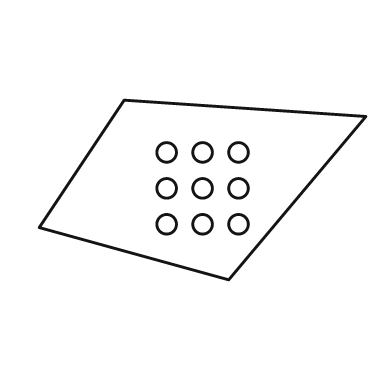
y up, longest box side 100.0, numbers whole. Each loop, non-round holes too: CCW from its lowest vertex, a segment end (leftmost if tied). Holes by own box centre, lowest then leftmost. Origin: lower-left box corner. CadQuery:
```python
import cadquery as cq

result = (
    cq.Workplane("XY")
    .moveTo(58.0, 0.0)
    .lineTo(100.0, 50.0)
    .lineTo(26.0, 55.0)
    .lineTo(0.0, 16.0)
    .close()
    .moveTo(39.0, 17.0)
    .circle(3.0)
    .moveTo(50.0, 17.0)
    .circle(3.0)
    .moveTo(61.0, 17.0)
    .circle(3.0)
    .moveTo(39.0, 28.0)
    .circle(3.0)
    .moveTo(50.0, 28.0)
    .circle(3.0)
    .moveTo(61.0, 28.0)
    .circle(3.0)
    .moveTo(39.0, 39.0)
    .circle(3.0)
    .moveTo(50.0, 39.0)
    .circle(3.0)
    .moveTo(61.0, 39.0)
    .circle(3.0)
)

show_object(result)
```